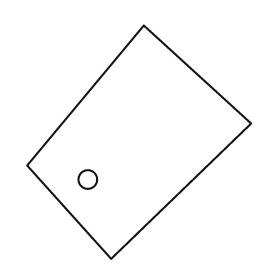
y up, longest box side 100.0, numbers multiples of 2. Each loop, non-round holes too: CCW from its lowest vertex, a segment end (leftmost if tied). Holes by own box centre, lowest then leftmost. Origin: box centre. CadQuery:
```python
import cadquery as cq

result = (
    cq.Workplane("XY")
    .moveTo(-12.0, -50.0)
    .lineTo(48.0, 8.0)
    .lineTo(2.0, 50.0)
    .lineTo(-48.0, -10.0)
    .close()
    .moveTo(-22.0, -16.0)
    .circle(4.0)
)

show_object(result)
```